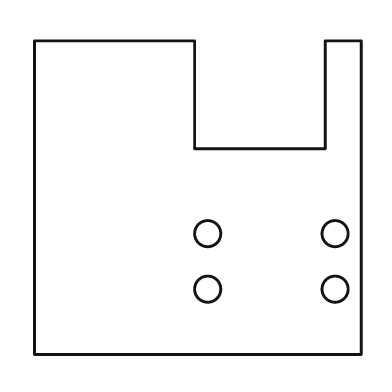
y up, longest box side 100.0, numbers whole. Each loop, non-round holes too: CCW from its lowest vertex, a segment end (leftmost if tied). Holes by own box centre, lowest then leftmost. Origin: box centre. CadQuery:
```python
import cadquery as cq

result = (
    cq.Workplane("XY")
    .moveTo(-50.0, -48.0)
    .lineTo(50.0, -48.0)
    .lineTo(50.0, 48.0)
    .lineTo(39.0, 48.0)
    .lineTo(39.0, 15.0)
    .lineTo(-1.0, 15.0)
    .lineTo(-1.0, 48.0)
    .lineTo(-50.0, 48.0)
    .close()
    .moveTo(3.0, -28.0)
    .circle(4.0)
    .moveTo(42.0, -28.0)
    .circle(4.0)
    .moveTo(3.0, -11.0)
    .circle(4.0)
    .moveTo(42.0, -11.0)
    .circle(4.0)
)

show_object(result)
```